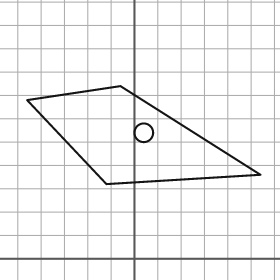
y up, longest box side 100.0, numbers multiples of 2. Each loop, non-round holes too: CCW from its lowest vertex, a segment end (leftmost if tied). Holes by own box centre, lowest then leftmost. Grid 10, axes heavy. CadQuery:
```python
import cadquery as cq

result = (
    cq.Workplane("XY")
    .moveTo(-12.0, 32.0)
    .lineTo(54.0, 36.0)
    .lineTo(-6.0, 74.0)
    .lineTo(-46.0, 68.0)
    .close()
    .moveTo(4.0, 54.0)
    .circle(4.0)
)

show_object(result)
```